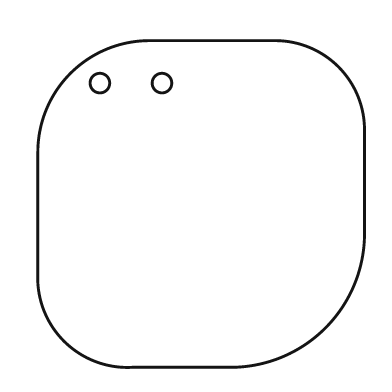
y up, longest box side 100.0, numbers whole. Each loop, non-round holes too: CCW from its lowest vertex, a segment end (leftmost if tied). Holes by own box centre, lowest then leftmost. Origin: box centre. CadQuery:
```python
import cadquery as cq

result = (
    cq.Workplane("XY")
    .moveTo(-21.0, -50.0)
    .lineTo(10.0, -50.0)
    .threePointArc((38.0, -38.0), (50.0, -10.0))
    .lineTo(50.0, 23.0)
    .threePointArc((42.0, 42.0), (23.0, 50.0))
    .lineTo(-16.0, 50.0)
    .threePointArc((-40.0, 40.0), (-50.0, 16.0))
    .lineTo(-50.0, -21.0)
    .threePointArc((-42.0, -42.0), (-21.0, -50.0))
    .close()
    .moveTo(-31.0, 37.0)
    .circle(3.0)
    .moveTo(-12.0, 37.0)
    .circle(3.0)
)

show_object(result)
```